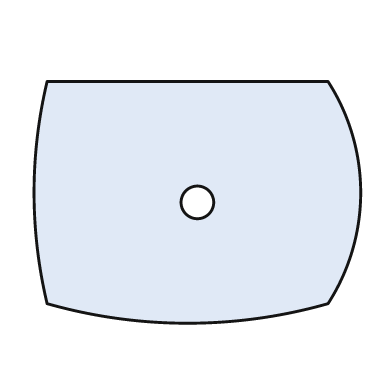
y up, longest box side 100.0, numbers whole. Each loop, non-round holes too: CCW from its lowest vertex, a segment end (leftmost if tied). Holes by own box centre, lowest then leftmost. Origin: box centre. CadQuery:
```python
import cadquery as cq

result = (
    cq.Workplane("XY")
    .moveTo(-46.0, -31.0)
    .threePointArc((-3.0, -37.0), (40.0, -31.0))
    .threePointArc((50.0, 3.0), (40.0, 37.0))
    .lineTo(-46.0, 37.0)
    .threePointArc((-50.0, 3.0), (-46.0, -31.0))
    .close()
    .moveTo(0.0, 0.0)
    .circle(5.0)
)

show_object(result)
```